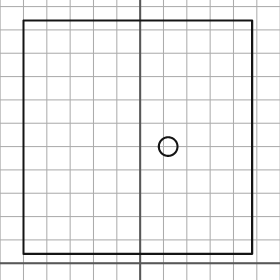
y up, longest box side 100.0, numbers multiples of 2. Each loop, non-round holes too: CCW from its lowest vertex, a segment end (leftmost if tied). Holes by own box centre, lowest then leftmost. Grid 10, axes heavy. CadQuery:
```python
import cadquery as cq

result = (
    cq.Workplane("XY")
    .moveTo(-50.0, 4.0)
    .lineTo(48.0, 4.0)
    .lineTo(48.0, 104.0)
    .lineTo(-50.0, 104.0)
    .close()
    .moveTo(12.0, 50.0)
    .circle(4.0)
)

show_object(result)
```